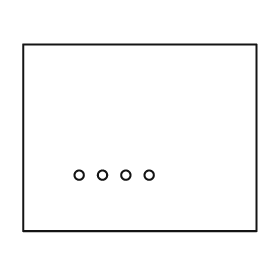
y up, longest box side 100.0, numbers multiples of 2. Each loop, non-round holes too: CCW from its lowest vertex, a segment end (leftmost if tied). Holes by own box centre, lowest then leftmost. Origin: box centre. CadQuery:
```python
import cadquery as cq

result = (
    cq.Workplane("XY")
    .moveTo(-50.0, -40.0)
    .lineTo(50.0, -40.0)
    .lineTo(50.0, 40.0)
    .lineTo(-50.0, 40.0)
    .close()
    .moveTo(-26.0, -16.0)
    .circle(2.0)
    .moveTo(-16.0, -16.0)
    .circle(2.0)
    .moveTo(-6.0, -16.0)
    .circle(2.0)
    .moveTo(4.0, -16.0)
    .circle(2.0)
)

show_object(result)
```